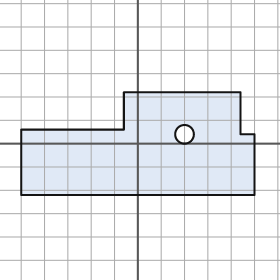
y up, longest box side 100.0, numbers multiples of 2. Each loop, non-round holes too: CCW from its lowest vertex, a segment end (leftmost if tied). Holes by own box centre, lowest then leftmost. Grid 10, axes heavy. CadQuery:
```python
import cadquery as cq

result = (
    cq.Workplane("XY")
    .moveTo(-50.0, -22.0)
    .lineTo(50.0, -22.0)
    .lineTo(50.0, 4.0)
    .lineTo(44.0, 4.0)
    .lineTo(44.0, 22.0)
    .lineTo(-6.0, 22.0)
    .lineTo(-6.0, 6.0)
    .lineTo(-50.0, 6.0)
    .close()
    .moveTo(20.0, 4.0)
    .circle(4.0)
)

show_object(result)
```